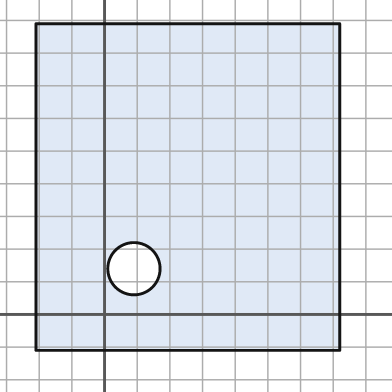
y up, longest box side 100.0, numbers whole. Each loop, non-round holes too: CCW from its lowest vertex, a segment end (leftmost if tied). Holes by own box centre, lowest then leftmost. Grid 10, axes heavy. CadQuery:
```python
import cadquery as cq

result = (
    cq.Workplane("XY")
    .moveTo(-21.0, -11.0)
    .lineTo(72.0, -11.0)
    .lineTo(72.0, 89.0)
    .lineTo(-21.0, 89.0)
    .close()
    .moveTo(9.0, 14.0)
    .circle(8.0)
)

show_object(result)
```